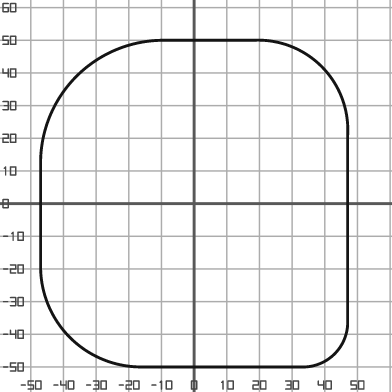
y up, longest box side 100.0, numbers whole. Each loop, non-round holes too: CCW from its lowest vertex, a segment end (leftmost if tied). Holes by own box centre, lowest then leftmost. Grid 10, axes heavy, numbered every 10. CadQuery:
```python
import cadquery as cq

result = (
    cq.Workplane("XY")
    .moveTo(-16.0, -50.0)
    .lineTo(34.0, -50.0)
    .threePointArc((43.0, -46.0), (47.0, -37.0))
    .lineTo(47.0, 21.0)
    .threePointArc((39.0, 42.0), (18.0, 50.0))
    .lineTo(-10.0, 50.0)
    .threePointArc((-36.0, 39.0), (-47.0, 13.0))
    .lineTo(-47.0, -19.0)
    .threePointArc((-38.0, -41.0), (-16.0, -50.0))
    .close()
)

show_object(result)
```